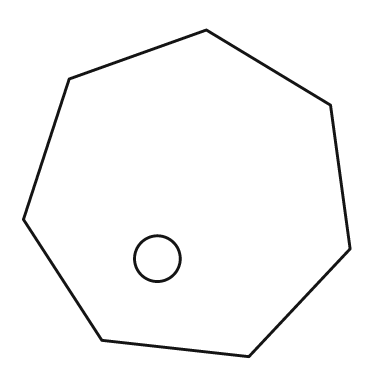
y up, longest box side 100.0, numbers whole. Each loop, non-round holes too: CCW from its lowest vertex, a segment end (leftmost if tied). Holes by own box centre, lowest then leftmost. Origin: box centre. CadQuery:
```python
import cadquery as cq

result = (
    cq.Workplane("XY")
    .moveTo(19.0, -50.0)
    .lineTo(50.0, -17.0)
    .lineTo(44.0, 27.0)
    .lineTo(6.0, 50.0)
    .lineTo(-36.0, 35.0)
    .lineTo(-50.0, -8.0)
    .lineTo(-26.0, -45.0)
    .close()
    .moveTo(-9.0, -20.0)
    .circle(7.0)
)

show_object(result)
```